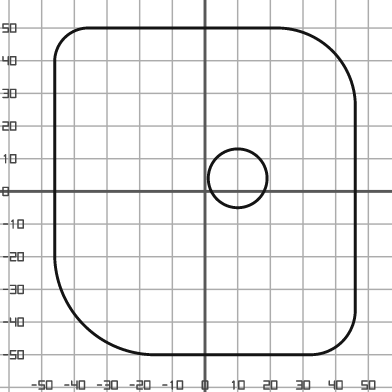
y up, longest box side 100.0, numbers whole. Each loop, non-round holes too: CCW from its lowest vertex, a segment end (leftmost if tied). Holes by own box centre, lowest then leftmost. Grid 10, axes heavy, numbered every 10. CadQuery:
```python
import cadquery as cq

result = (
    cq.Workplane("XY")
    .moveTo(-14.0, -50.0)
    .lineTo(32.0, -50.0)
    .threePointArc((42.0, -46.0), (46.0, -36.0))
    .lineTo(46.0, 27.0)
    .threePointArc((39.0, 43.0), (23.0, 50.0))
    .lineTo(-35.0, 50.0)
    .threePointArc((-43.0, 47.0), (-46.0, 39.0))
    .lineTo(-46.0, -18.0)
    .threePointArc((-37.0, -41.0), (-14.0, -50.0))
    .close()
    .moveTo(10.0, 4.0)
    .circle(9.0)
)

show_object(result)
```